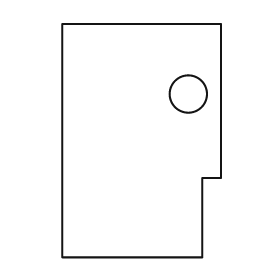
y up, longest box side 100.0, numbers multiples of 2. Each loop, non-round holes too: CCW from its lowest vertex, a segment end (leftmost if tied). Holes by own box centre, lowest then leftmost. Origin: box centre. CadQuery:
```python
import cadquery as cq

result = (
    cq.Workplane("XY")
    .moveTo(-34.0, -50.0)
    .lineTo(26.0, -50.0)
    .lineTo(26.0, -16.0)
    .lineTo(34.0, -16.0)
    .lineTo(34.0, 50.0)
    .lineTo(-34.0, 50.0)
    .close()
    .moveTo(20.0, 20.0)
    .circle(8.0)
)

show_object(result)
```